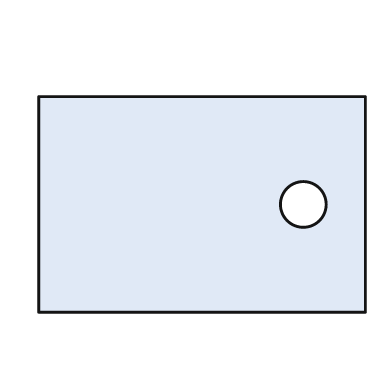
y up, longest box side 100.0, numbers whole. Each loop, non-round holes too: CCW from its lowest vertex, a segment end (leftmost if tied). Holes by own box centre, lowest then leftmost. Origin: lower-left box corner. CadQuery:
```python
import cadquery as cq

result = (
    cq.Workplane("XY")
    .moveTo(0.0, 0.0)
    .lineTo(100.0, 0.0)
    .lineTo(100.0, 66.0)
    .lineTo(0.0, 66.0)
    .close()
    .moveTo(81.0, 33.0)
    .circle(7.0)
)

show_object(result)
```